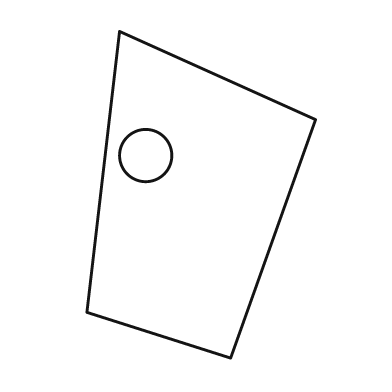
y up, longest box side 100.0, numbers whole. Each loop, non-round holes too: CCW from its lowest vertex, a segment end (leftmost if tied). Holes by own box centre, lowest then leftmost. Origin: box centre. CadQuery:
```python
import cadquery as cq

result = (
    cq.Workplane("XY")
    .moveTo(9.0, -50.0)
    .lineTo(35.0, 23.0)
    .lineTo(-25.0, 50.0)
    .lineTo(-35.0, -36.0)
    .close()
    .moveTo(-17.0, 12.0)
    .circle(8.0)
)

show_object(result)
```